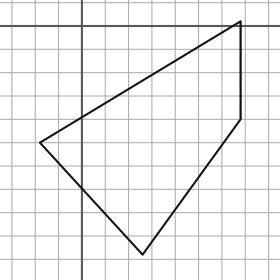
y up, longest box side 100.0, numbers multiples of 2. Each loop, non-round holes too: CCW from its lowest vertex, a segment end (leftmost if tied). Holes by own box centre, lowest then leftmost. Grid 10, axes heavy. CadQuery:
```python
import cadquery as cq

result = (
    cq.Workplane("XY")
    .moveTo(26.0, -98.0)
    .lineTo(68.0, -40.0)
    .lineTo(68.0, 2.0)
    .lineTo(-18.0, -50.0)
    .close()
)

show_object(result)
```